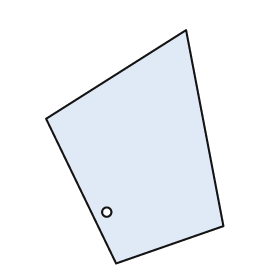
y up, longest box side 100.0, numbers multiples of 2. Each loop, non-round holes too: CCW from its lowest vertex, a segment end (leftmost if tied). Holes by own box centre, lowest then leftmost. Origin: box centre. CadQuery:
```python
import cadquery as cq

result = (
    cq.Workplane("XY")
    .moveTo(-8.0, -50.0)
    .lineTo(38.0, -34.0)
    .lineTo(22.0, 50.0)
    .lineTo(-38.0, 12.0)
    .close()
    .moveTo(-12.0, -28.0)
    .circle(2.0)
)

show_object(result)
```